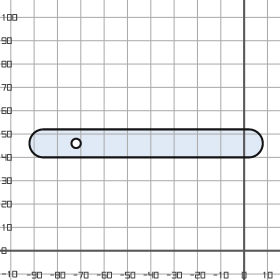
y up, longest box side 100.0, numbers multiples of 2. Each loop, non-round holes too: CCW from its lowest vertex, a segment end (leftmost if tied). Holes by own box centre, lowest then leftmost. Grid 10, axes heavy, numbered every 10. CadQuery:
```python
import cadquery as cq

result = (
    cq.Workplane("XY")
    .moveTo(-86.0, 40.0)
    .lineTo(2.0, 40.0)
    .threePointArc((8.0, 46.0), (2.0, 52.0))
    .lineTo(-86.0, 52.0)
    .threePointArc((-92.0, 46.0), (-86.0, 40.0))
    .close()
    .moveTo(-72.0, 46.0)
    .circle(2.0)
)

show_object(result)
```